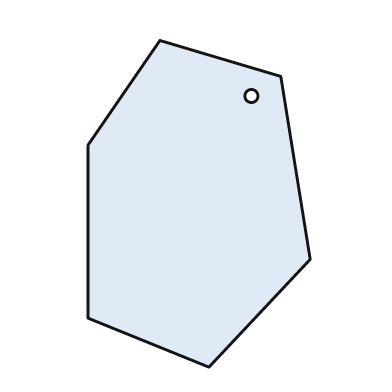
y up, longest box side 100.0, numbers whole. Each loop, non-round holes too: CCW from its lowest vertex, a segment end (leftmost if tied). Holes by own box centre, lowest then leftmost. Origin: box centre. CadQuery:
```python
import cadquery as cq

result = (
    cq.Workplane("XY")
    .moveTo(3.0, -50.0)
    .lineTo(34.0, -17.0)
    .lineTo(25.0, 39.0)
    .lineTo(-12.0, 50.0)
    .lineTo(-34.0, 18.0)
    .lineTo(-34.0, -35.0)
    .close()
    .moveTo(16.0, 33.0)
    .circle(2.0)
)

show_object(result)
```